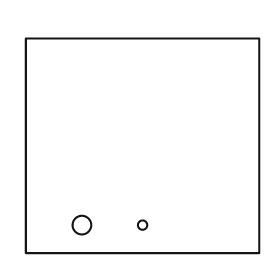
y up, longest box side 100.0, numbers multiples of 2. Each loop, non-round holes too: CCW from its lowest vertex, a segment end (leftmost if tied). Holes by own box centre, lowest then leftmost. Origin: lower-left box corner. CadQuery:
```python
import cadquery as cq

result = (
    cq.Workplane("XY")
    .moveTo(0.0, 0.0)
    .lineTo(100.0, 0.0)
    .lineTo(100.0, 92.0)
    .lineTo(0.0, 92.0)
    .close()
    .moveTo(24.0, 12.0)
    .circle(4.0)
    .moveTo(50.0, 12.0)
    .circle(2.0)
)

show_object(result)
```